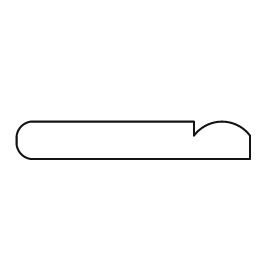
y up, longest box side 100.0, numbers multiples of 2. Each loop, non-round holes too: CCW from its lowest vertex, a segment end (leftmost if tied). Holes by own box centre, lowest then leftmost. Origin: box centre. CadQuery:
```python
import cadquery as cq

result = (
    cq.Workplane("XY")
    .moveTo(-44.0, -8.0)
    .lineTo(50.0, -8.0)
    .lineTo(50.0, 2.0)
    .threePointArc((38.0, 8.0), (26.0, 2.0))
    .lineTo(26.0, 8.0)
    .lineTo(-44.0, 8.0)
    .threePointArc((-48.0, 6.0), (-50.0, 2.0))
    .lineTo(-50.0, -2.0)
    .threePointArc((-48.0, -6.0), (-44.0, -8.0))
    .close()
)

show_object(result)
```